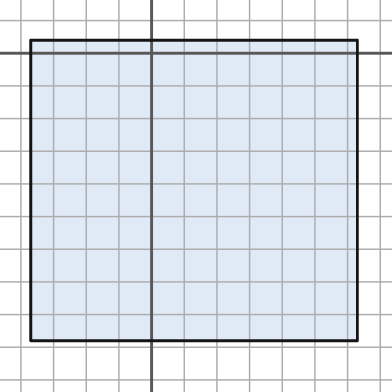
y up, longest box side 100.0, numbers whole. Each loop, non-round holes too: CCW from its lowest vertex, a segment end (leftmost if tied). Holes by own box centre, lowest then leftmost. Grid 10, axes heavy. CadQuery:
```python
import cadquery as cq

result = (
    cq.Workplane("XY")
    .moveTo(-37.0, -88.0)
    .lineTo(63.0, -88.0)
    .lineTo(63.0, 4.0)
    .lineTo(-37.0, 4.0)
    .close()
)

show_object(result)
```